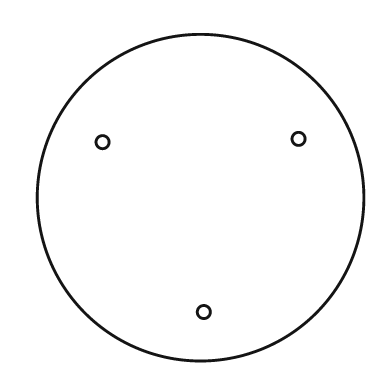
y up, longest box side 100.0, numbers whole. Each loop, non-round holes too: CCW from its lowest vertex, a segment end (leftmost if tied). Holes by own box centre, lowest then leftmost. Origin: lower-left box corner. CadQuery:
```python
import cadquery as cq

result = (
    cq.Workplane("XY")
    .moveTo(50.0, 50.0)
    .circle(50.0)
    .moveTo(51.0, 15.0)
    .circle(2.0)
    .moveTo(20.0, 67.0)
    .circle(2.0)
    .moveTo(80.0, 68.0)
    .circle(2.0)
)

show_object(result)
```